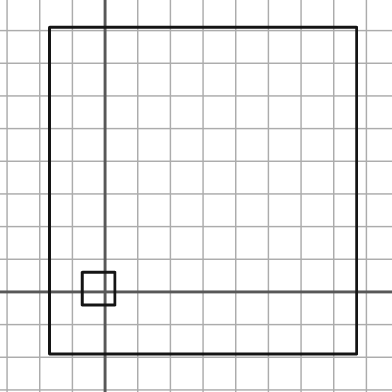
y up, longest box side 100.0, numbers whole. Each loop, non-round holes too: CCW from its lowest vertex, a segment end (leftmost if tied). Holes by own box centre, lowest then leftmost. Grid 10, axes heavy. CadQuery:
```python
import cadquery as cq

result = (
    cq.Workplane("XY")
    .moveTo(-17.0, -19.0)
    .lineTo(77.0, -19.0)
    .lineTo(77.0, 81.0)
    .lineTo(-17.0, 81.0)
    .close()
    .moveTo(-7.0, -4.0)
    .lineTo(3.0, -4.0)
    .lineTo(3.0, 6.0)
    .lineTo(-7.0, 6.0)
    .close()
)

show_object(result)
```